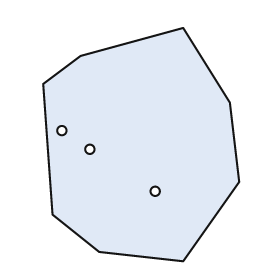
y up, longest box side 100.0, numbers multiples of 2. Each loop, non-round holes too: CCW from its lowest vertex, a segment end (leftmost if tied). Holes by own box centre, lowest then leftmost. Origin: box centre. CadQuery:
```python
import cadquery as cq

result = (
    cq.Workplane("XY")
    .moveTo(18.0, -50.0)
    .lineTo(42.0, -16.0)
    .lineTo(38.0, 18.0)
    .lineTo(18.0, 50.0)
    .lineTo(-26.0, 38.0)
    .lineTo(-42.0, 26.0)
    .lineTo(-38.0, -30.0)
    .lineTo(-18.0, -46.0)
    .close()
    .moveTo(6.0, -20.0)
    .circle(2.0)
    .moveTo(-22.0, -2.0)
    .circle(2.0)
    .moveTo(-34.0, 6.0)
    .circle(2.0)
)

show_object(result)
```